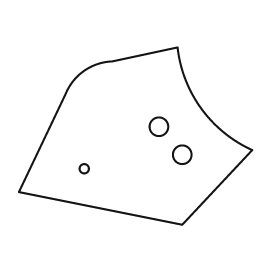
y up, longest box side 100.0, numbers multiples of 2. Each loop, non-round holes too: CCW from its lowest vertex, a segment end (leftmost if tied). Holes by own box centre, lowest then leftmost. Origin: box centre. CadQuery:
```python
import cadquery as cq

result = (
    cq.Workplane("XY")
    .moveTo(20.0, -38.0)
    .lineTo(50.0, -6.0)
    .threePointArc((28.0, 12.0), (18.0, 38.0))
    .lineTo(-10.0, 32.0)
    .threePointArc((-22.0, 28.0), (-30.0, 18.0))
    .lineTo(-50.0, -24.0)
    .close()
    .moveTo(-22.0, -14.0)
    .circle(2.0)
    .moveTo(20.0, -8.0)
    .circle(4.0)
    .moveTo(10.0, 4.0)
    .circle(4.0)
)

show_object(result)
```